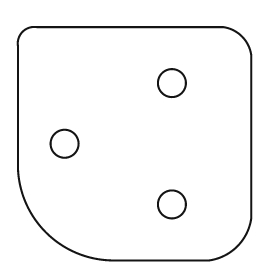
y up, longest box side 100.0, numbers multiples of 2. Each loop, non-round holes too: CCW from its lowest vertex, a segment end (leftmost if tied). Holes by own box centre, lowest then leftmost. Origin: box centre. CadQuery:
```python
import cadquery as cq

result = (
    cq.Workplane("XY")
    .moveTo(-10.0, -50.0)
    .lineTo(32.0, -50.0)
    .threePointArc((44.0, -44.0), (50.0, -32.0))
    .lineTo(50.0, 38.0)
    .threePointArc((46.0, 46.0), (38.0, 50.0))
    .lineTo(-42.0, 50.0)
    .threePointArc((-48.0, 48.0), (-50.0, 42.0))
    .lineTo(-50.0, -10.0)
    .threePointArc((-38.0, -38.0), (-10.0, -50.0))
    .close()
    .moveTo(16.0, -26.0)
    .circle(6.0)
    .moveTo(-30.0, 0.0)
    .circle(6.0)
    .moveTo(16.0, 26.0)
    .circle(6.0)
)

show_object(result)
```